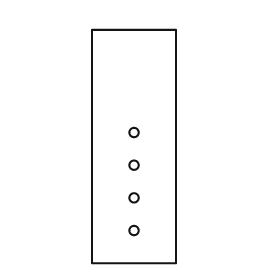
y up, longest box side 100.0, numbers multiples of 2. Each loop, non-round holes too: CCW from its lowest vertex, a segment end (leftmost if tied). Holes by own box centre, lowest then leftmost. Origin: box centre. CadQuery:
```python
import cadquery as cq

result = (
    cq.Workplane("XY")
    .moveTo(-18.0, -50.0)
    .lineTo(18.0, -50.0)
    .lineTo(18.0, 50.0)
    .lineTo(-18.0, 50.0)
    .close()
    .moveTo(0.0, -36.0)
    .circle(2.0)
    .moveTo(0.0, -22.0)
    .circle(2.0)
    .moveTo(0.0, -8.0)
    .circle(2.0)
    .moveTo(0.0, 6.0)
    .circle(2.0)
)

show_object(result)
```